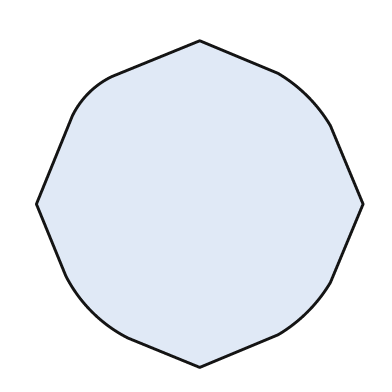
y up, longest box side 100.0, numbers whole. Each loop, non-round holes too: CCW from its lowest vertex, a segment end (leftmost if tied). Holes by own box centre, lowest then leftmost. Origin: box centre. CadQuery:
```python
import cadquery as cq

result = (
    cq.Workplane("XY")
    .moveTo(0.0, -50.0)
    .lineTo(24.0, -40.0)
    .threePointArc((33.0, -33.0), (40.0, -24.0))
    .lineTo(50.0, 0.0)
    .lineTo(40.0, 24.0)
    .threePointArc((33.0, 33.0), (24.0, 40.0))
    .lineTo(0.0, 50.0)
    .lineTo(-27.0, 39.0)
    .threePointArc((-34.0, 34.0), (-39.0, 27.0))
    .lineTo(-50.0, 0.0)
    .lineTo(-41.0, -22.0)
    .threePointArc((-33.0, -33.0), (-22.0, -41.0))
    .close()
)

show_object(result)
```